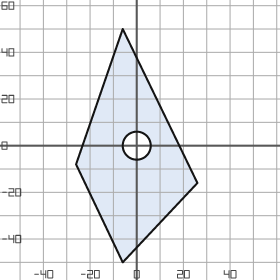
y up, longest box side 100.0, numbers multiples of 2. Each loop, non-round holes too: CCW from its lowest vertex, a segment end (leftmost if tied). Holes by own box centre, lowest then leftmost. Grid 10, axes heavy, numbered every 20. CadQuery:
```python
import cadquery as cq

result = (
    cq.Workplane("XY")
    .moveTo(-6.0, -50.0)
    .lineTo(26.0, -16.0)
    .lineTo(-6.0, 50.0)
    .lineTo(-26.0, -8.0)
    .close()
    .moveTo(0.0, 0.0)
    .circle(6.0)
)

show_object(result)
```